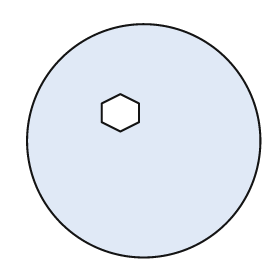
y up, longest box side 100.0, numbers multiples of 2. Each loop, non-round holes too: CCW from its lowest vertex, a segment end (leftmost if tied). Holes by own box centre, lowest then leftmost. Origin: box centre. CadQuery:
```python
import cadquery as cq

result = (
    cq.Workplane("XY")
    .moveTo(0.0, 0.0)
    .circle(50.0)
    .moveTo(-10.0, 4.0)
    .lineTo(-2.0, 8.0)
    .lineTo(-2.0, 16.0)
    .lineTo(-10.0, 20.0)
    .lineTo(-18.0, 16.0)
    .lineTo(-18.0, 8.0)
    .close()
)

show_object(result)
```